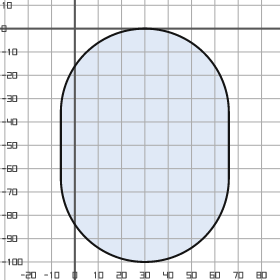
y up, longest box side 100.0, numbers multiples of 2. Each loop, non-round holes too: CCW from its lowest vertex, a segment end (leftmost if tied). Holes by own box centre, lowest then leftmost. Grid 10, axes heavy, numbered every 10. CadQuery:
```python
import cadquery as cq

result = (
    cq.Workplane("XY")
    .moveTo(-6.0, -64.0)
    .threePointArc((30.0, -100.0), (66.0, -64.0))
    .lineTo(66.0, -36.0)
    .threePointArc((30.0, 0.0), (-6.0, -36.0))
    .close()
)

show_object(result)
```